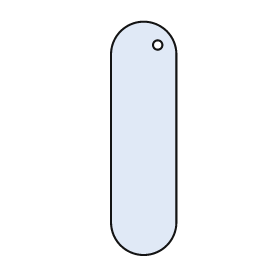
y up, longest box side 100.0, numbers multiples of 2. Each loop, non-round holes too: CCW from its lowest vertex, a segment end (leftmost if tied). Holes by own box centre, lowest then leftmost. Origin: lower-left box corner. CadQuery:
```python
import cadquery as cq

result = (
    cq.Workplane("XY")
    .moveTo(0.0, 14.0)
    .threePointArc((14.0, 0.0), (28.0, 14.0))
    .lineTo(28.0, 86.0)
    .threePointArc((14.0, 100.0), (0.0, 86.0))
    .close()
    .moveTo(20.0, 90.0)
    .circle(2.0)
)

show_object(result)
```